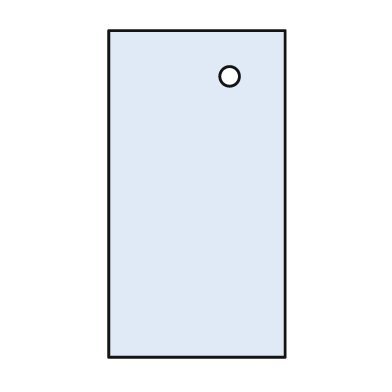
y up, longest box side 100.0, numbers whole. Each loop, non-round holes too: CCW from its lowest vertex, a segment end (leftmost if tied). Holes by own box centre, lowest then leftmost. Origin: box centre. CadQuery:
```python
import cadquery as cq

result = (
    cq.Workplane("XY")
    .moveTo(-27.0, -50.0)
    .lineTo(27.0, -50.0)
    .lineTo(27.0, 50.0)
    .lineTo(-27.0, 50.0)
    .close()
    .moveTo(10.0, 36.0)
    .circle(3.0)
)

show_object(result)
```